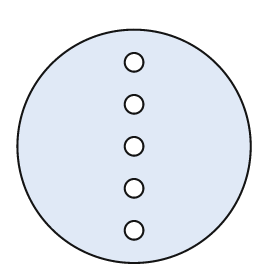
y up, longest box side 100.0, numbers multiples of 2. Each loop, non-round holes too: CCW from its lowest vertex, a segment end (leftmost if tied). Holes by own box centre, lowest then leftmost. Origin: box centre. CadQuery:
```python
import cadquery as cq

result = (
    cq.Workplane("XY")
    .moveTo(0.0, 0.0)
    .circle(50.0)
    .moveTo(0.0, -36.0)
    .circle(4.0)
    .moveTo(0.0, -18.0)
    .circle(4.0)
    .moveTo(0.0, 0.0)
    .circle(4.0)
    .moveTo(0.0, 18.0)
    .circle(4.0)
    .moveTo(0.0, 36.0)
    .circle(4.0)
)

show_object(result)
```